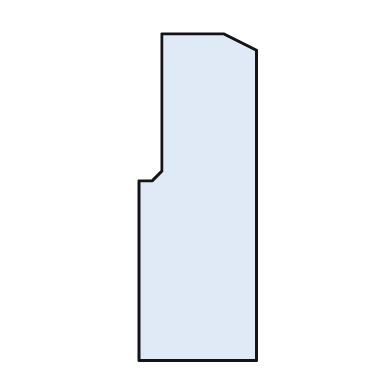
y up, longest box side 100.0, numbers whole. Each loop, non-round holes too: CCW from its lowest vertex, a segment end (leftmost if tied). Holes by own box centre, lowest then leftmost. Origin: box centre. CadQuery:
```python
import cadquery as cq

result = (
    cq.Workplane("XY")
    .moveTo(-18.0, -50.0)
    .lineTo(18.0, -50.0)
    .lineTo(18.0, 45.0)
    .lineTo(8.0, 50.0)
    .lineTo(-11.0, 50.0)
    .lineTo(-11.0, 8.0)
    .lineTo(-14.0, 5.0)
    .lineTo(-18.0, 5.0)
    .close()
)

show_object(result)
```